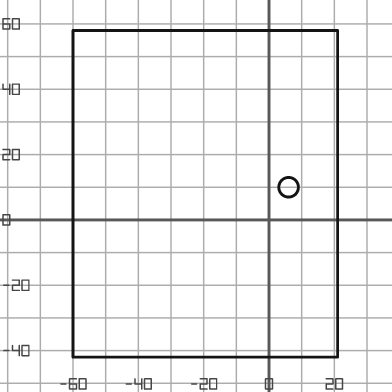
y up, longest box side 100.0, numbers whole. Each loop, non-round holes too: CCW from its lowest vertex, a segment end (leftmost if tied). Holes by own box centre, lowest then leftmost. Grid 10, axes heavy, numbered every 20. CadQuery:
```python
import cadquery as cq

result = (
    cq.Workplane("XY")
    .moveTo(-60.0, -42.0)
    .lineTo(21.0, -42.0)
    .lineTo(21.0, 58.0)
    .lineTo(-60.0, 58.0)
    .close()
    .moveTo(6.0, 10.0)
    .circle(3.0)
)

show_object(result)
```